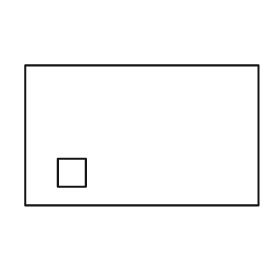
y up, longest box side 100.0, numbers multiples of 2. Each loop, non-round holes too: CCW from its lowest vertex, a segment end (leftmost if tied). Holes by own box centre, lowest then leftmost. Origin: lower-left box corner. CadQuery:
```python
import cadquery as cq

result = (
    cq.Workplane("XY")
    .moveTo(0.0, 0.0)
    .lineTo(100.0, 0.0)
    .lineTo(100.0, 60.0)
    .lineTo(0.0, 60.0)
    .close()
    .moveTo(14.0, 8.0)
    .lineTo(26.0, 8.0)
    .lineTo(26.0, 20.0)
    .lineTo(14.0, 20.0)
    .close()
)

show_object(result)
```